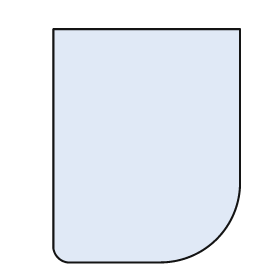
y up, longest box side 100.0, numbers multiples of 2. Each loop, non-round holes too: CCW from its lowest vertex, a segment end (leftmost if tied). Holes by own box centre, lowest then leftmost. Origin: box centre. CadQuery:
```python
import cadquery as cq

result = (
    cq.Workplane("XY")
    .moveTo(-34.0, -50.0)
    .lineTo(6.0, -50.0)
    .threePointArc((30.0, -40.0), (40.0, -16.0))
    .lineTo(40.0, 50.0)
    .lineTo(-40.0, 50.0)
    .lineTo(-40.0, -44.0)
    .threePointArc((-38.0, -48.0), (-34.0, -50.0))
    .close()
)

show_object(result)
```